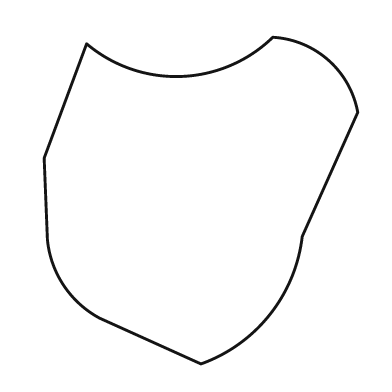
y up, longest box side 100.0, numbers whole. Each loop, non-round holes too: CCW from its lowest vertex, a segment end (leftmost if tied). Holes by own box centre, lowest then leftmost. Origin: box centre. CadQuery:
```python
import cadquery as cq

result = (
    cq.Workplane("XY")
    .moveTo(0.0, -50.0)
    .threePointArc((21.0, -35.0), (31.0, -11.0))
    .lineTo(48.0, 27.0)
    .threePointArc((39.0, 43.0), (22.0, 50.0))
    .threePointArc((-6.0, 38.0), (-35.0, 48.0))
    .lineTo(-48.0, 13.0)
    .lineTo(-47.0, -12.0)
    .threePointArc((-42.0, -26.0), (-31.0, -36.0))
    .close()
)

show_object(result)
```